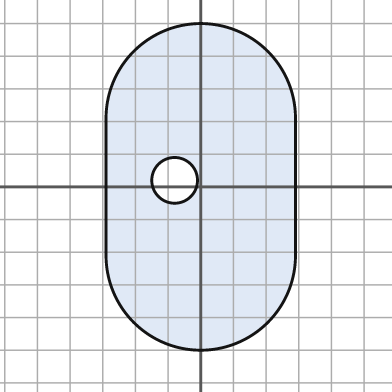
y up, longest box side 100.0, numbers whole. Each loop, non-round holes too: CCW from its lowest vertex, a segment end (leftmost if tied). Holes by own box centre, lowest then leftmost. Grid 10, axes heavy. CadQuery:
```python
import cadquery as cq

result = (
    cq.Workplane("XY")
    .moveTo(-29.0, -21.0)
    .threePointArc((0.0, -50.0), (29.0, -21.0))
    .lineTo(29.0, 21.0)
    .threePointArc((0.0, 50.0), (-29.0, 21.0))
    .close()
    .moveTo(-8.0, 2.0)
    .circle(7.0)
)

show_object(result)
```